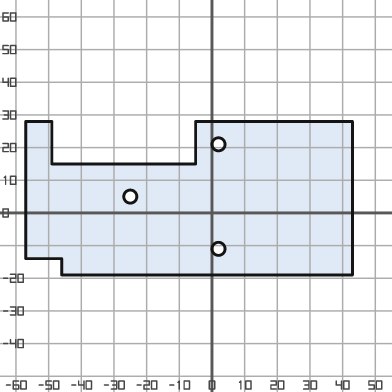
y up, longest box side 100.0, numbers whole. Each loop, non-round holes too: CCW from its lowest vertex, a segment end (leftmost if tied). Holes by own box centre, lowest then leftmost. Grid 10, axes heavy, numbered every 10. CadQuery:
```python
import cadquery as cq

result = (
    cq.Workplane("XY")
    .moveTo(-46.0, -19.0)
    .lineTo(43.0, -19.0)
    .lineTo(43.0, 28.0)
    .lineTo(-5.0, 28.0)
    .lineTo(-5.0, 15.0)
    .lineTo(-49.0, 15.0)
    .lineTo(-49.0, 28.0)
    .lineTo(-57.0, 28.0)
    .lineTo(-57.0, -14.0)
    .lineTo(-46.0, -14.0)
    .close()
    .moveTo(2.0, -11.0)
    .circle(2.0)
    .moveTo(-25.0, 5.0)
    .circle(2.0)
    .moveTo(2.0, 21.0)
    .circle(2.0)
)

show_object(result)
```